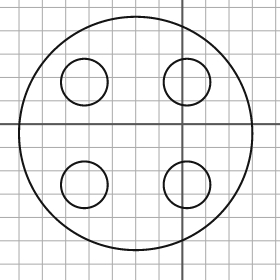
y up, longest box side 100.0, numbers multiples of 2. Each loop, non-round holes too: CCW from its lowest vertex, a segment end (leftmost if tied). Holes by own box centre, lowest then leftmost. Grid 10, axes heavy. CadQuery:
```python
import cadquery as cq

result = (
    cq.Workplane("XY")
    .moveTo(-20.0, -4.0)
    .circle(50.0)
    .moveTo(-42.0, -26.0)
    .circle(10.0)
    .moveTo(2.0, -26.0)
    .circle(10.0)
    .moveTo(-42.0, 18.0)
    .circle(10.0)
    .moveTo(2.0, 18.0)
    .circle(10.0)
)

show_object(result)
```